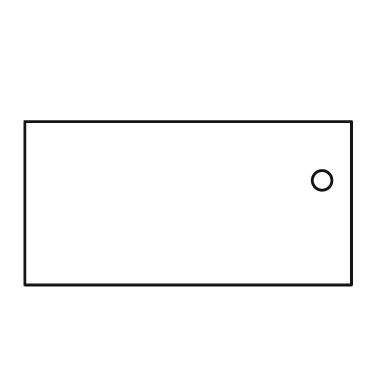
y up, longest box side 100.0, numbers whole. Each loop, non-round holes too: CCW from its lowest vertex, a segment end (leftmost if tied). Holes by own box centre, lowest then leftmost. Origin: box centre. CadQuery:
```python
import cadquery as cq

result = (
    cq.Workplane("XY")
    .moveTo(-50.0, -25.0)
    .lineTo(50.0, -25.0)
    .lineTo(50.0, 25.0)
    .lineTo(-50.0, 25.0)
    .close()
    .moveTo(41.0, 7.0)
    .circle(3.0)
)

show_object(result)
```